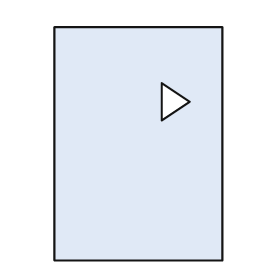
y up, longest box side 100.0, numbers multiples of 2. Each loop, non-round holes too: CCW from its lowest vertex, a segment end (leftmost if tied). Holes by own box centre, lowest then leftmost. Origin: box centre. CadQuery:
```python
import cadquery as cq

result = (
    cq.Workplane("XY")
    .moveTo(-36.0, -50.0)
    .lineTo(36.0, -50.0)
    .lineTo(36.0, 50.0)
    .lineTo(-36.0, 50.0)
    .close()
    .moveTo(10.0, 10.0)
    .lineTo(22.0, 18.0)
    .lineTo(10.0, 26.0)
    .close()
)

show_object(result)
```